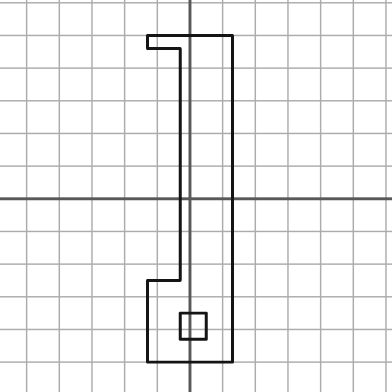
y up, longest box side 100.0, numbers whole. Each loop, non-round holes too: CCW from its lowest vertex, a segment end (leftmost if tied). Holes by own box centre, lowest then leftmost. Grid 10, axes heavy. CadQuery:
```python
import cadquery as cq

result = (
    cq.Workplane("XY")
    .moveTo(-13.0, -50.0)
    .lineTo(13.0, -50.0)
    .lineTo(13.0, 50.0)
    .lineTo(-13.0, 50.0)
    .lineTo(-13.0, 46.0)
    .lineTo(-3.0, 46.0)
    .lineTo(-3.0, -25.0)
    .lineTo(-13.0, -25.0)
    .close()
    .moveTo(-3.0, -43.0)
    .lineTo(5.0, -43.0)
    .lineTo(5.0, -35.0)
    .lineTo(-3.0, -35.0)
    .close()
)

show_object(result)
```